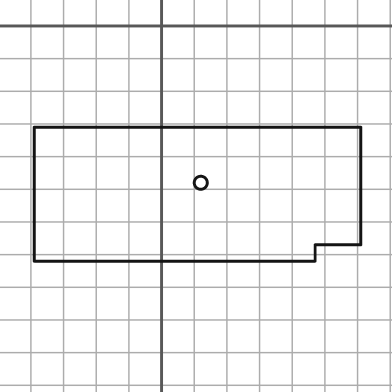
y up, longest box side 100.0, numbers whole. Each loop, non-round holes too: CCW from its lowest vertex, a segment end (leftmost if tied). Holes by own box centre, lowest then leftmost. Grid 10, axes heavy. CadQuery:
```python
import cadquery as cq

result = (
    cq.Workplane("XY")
    .moveTo(-39.0, -72.0)
    .lineTo(47.0, -72.0)
    .lineTo(47.0, -67.0)
    .lineTo(61.0, -67.0)
    .lineTo(61.0, -31.0)
    .lineTo(-39.0, -31.0)
    .close()
    .moveTo(12.0, -48.0)
    .circle(2.0)
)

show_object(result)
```